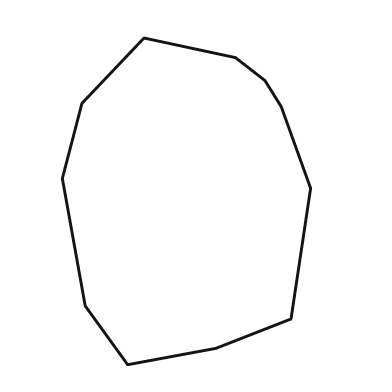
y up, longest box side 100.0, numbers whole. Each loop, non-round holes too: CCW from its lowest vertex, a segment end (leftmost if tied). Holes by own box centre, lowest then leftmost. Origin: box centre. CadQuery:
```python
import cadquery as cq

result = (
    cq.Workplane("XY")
    .moveTo(-18.0, -50.0)
    .lineTo(9.0, -45.0)
    .lineTo(32.0, -36.0)
    .lineTo(38.0, 4.0)
    .lineTo(29.0, 29.0)
    .lineTo(24.0, 37.0)
    .lineTo(15.0, 44.0)
    .lineTo(-13.0, 50.0)
    .lineTo(-32.0, 30.0)
    .lineTo(-38.0, 7.0)
    .lineTo(-31.0, -32.0)
    .close()
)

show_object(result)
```